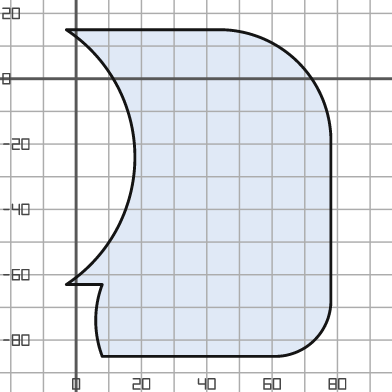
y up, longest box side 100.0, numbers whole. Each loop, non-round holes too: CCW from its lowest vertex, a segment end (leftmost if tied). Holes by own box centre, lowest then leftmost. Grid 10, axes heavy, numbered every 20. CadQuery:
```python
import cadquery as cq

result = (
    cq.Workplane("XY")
    .moveTo(8.0, -85.0)
    .lineTo(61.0, -85.0)
    .threePointArc((73.0, -80.0), (78.0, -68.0))
    .lineTo(78.0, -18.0)
    .threePointArc((68.0, 5.0), (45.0, 15.0))
    .lineTo(-3.0, 15.0)
    .threePointArc((18.0, -24.0), (-3.0, -63.0))
    .lineTo(8.0, -63.0)
    .threePointArc((6.0, -74.0), (8.0, -85.0))
    .close()
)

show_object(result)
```